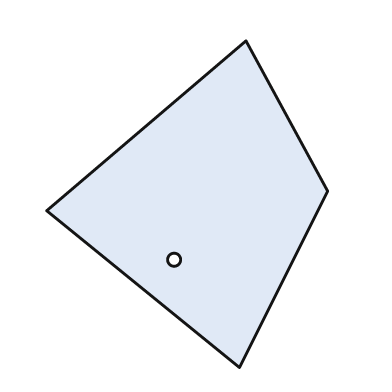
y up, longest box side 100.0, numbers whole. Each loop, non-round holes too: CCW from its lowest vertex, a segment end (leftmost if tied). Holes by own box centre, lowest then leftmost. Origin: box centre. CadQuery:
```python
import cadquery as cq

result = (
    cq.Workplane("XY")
    .moveTo(16.0, -50.0)
    .lineTo(43.0, 4.0)
    .lineTo(18.0, 50.0)
    .lineTo(-43.0, -2.0)
    .close()
    .moveTo(-4.0, -17.0)
    .circle(2.0)
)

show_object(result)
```